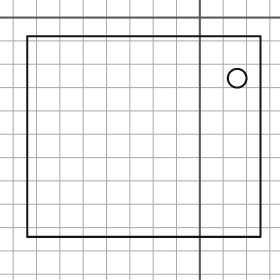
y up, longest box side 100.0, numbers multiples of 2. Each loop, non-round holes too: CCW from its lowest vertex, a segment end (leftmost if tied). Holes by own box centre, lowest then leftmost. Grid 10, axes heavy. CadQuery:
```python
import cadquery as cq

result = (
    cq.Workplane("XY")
    .moveTo(-74.0, -94.0)
    .lineTo(26.0, -94.0)
    .lineTo(26.0, -8.0)
    .lineTo(-74.0, -8.0)
    .close()
    .moveTo(16.0, -26.0)
    .circle(4.0)
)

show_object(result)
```